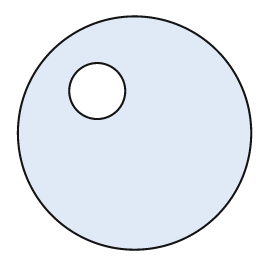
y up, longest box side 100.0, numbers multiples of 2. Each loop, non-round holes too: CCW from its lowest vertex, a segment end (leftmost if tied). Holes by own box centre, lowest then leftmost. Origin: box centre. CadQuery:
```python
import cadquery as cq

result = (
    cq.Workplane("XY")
    .moveTo(0.0, 0.0)
    .circle(50.0)
    .moveTo(-16.0, 18.0)
    .circle(12.0)
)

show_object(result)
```